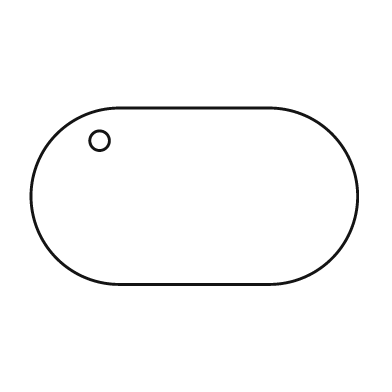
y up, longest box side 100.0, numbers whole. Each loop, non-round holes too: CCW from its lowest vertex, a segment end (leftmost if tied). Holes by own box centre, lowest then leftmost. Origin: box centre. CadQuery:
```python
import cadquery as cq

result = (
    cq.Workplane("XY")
    .moveTo(-23.0, -27.0)
    .lineTo(23.0, -27.0)
    .threePointArc((50.0, 0.0), (23.0, 27.0))
    .lineTo(-23.0, 27.0)
    .threePointArc((-50.0, 0.0), (-23.0, -27.0))
    .close()
    .moveTo(-29.0, 17.0)
    .circle(3.0)
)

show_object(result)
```